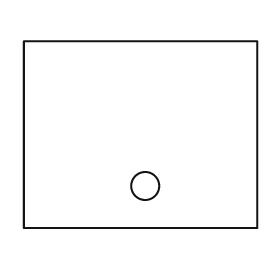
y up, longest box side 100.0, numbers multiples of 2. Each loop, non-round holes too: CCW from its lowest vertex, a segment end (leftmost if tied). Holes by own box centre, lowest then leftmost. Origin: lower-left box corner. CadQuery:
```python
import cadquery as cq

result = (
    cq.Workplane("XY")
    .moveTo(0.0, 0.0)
    .lineTo(100.0, 0.0)
    .lineTo(100.0, 80.0)
    .lineTo(0.0, 80.0)
    .close()
    .moveTo(52.0, 18.0)
    .circle(6.0)
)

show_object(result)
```